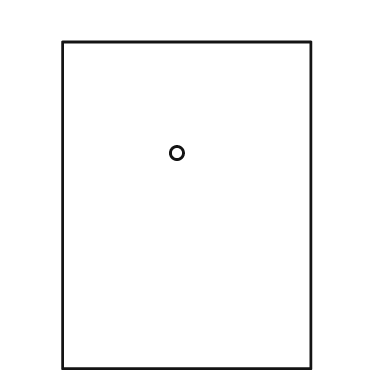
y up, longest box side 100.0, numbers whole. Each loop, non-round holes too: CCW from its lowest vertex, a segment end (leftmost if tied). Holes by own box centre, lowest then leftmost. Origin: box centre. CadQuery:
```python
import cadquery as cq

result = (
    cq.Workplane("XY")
    .moveTo(-38.0, -50.0)
    .lineTo(38.0, -50.0)
    .lineTo(38.0, 50.0)
    .lineTo(-38.0, 50.0)
    .close()
    .moveTo(-3.0, 16.0)
    .circle(2.0)
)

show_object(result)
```